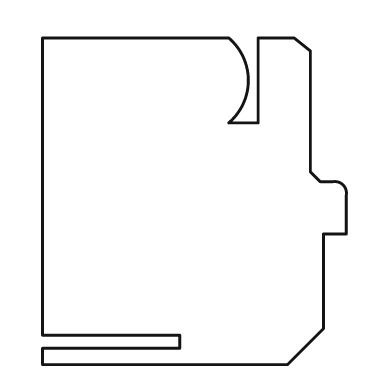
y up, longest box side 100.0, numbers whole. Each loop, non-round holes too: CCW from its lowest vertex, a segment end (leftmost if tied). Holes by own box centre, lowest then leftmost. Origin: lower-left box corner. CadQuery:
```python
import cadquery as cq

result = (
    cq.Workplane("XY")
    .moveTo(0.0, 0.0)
    .lineTo(75.0, 0.0)
    .lineTo(86.0, 11.0)
    .lineTo(86.0, 40.0)
    .lineTo(93.0, 40.0)
    .lineTo(93.0, 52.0)
    .threePointArc((92.0, 55.0), (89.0, 56.0))
    .lineTo(85.0, 56.0)
    .lineTo(82.0, 59.0)
    .lineTo(82.0, 96.0)
    .lineTo(77.0, 100.0)
    .lineTo(66.0, 100.0)
    .lineTo(66.0, 74.0)
    .lineTo(57.0, 74.0)
    .threePointArc((63.0, 87.0), (57.0, 100.0))
    .lineTo(0.0, 100.0)
    .lineTo(0.0, 9.0)
    .lineTo(42.0, 9.0)
    .lineTo(42.0, 5.0)
    .lineTo(0.0, 5.0)
    .close()
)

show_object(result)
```